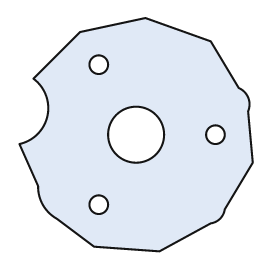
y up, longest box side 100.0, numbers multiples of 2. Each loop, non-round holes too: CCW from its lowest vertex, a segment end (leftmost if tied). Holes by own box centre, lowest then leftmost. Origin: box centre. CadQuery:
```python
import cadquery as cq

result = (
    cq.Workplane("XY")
    .moveTo(10.0, -50.0)
    .lineTo(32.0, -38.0)
    .threePointArc((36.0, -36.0), (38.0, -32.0))
    .lineTo(50.0, -12.0)
    .lineTo(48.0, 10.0)
    .threePointArc((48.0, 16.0), (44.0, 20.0))
    .lineTo(32.0, 40.0)
    .lineTo(4.0, 50.0)
    .lineTo(-24.0, 44.0)
    .lineTo(-44.0, 24.0)
    .threePointArc((-38.0, 8.0), (-50.0, -4.0))
    .lineTo(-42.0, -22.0)
    .threePointArc((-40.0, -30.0), (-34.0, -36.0))
    .lineTo(-18.0, -48.0)
    .close()
    .moveTo(-16.0, -30.0)
    .circle(4.0)
    .moveTo(0.0, 0.0)
    .circle(12.0)
    .moveTo(34.0, 0.0)
    .circle(4.0)
    .moveTo(-16.0, 30.0)
    .circle(4.0)
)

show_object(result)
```